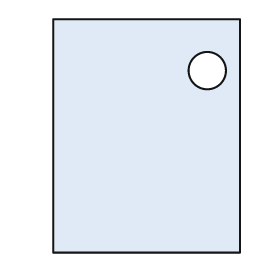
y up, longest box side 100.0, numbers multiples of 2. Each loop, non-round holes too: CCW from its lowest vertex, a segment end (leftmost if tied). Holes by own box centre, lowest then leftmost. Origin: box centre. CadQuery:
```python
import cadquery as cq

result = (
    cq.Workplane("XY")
    .moveTo(-40.0, -50.0)
    .lineTo(40.0, -50.0)
    .lineTo(40.0, 50.0)
    .lineTo(-40.0, 50.0)
    .close()
    .moveTo(26.0, 28.0)
    .circle(8.0)
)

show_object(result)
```